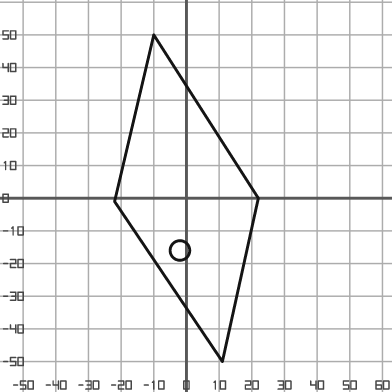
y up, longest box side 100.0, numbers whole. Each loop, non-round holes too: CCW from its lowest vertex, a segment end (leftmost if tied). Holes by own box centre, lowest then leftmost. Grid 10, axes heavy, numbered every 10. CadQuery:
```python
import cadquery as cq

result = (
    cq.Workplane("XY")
    .moveTo(11.0, -50.0)
    .lineTo(22.0, 0.0)
    .lineTo(-10.0, 50.0)
    .lineTo(-22.0, -1.0)
    .close()
    .moveTo(-2.0, -16.0)
    .circle(3.0)
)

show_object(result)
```